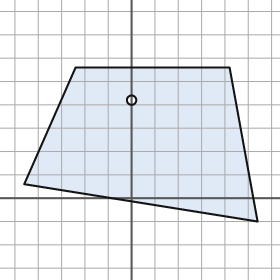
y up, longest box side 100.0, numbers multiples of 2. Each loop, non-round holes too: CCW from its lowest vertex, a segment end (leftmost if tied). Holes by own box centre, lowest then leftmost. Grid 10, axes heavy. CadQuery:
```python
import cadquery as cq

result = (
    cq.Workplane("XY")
    .moveTo(54.0, -10.0)
    .lineTo(42.0, 56.0)
    .lineTo(-24.0, 56.0)
    .lineTo(-46.0, 6.0)
    .close()
    .moveTo(0.0, 42.0)
    .circle(2.0)
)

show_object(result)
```